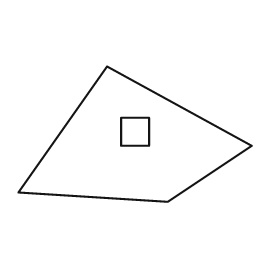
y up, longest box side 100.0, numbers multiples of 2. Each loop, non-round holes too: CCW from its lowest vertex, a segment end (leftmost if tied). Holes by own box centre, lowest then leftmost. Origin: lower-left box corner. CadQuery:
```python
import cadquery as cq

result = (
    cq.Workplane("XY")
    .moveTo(64.0, 0.0)
    .lineTo(100.0, 24.0)
    .lineTo(38.0, 58.0)
    .lineTo(0.0, 4.0)
    .close()
    .moveTo(44.0, 24.0)
    .lineTo(56.0, 24.0)
    .lineTo(56.0, 36.0)
    .lineTo(44.0, 36.0)
    .close()
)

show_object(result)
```